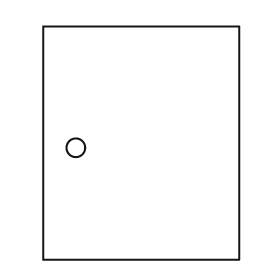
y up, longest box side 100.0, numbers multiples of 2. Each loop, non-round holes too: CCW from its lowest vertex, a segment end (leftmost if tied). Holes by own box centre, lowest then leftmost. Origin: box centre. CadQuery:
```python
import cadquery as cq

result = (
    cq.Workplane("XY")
    .moveTo(-42.0, -50.0)
    .lineTo(42.0, -50.0)
    .lineTo(42.0, 50.0)
    .lineTo(-42.0, 50.0)
    .close()
    .moveTo(-28.0, -2.0)
    .circle(4.0)
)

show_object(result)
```